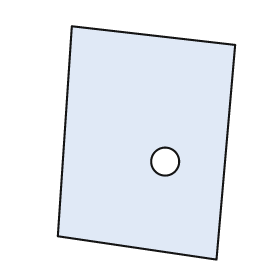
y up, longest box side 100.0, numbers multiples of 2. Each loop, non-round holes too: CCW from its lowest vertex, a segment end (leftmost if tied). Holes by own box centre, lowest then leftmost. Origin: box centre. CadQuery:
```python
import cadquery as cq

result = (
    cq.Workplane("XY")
    .moveTo(30.0, -50.0)
    .lineTo(38.0, 42.0)
    .lineTo(-32.0, 50.0)
    .lineTo(-38.0, -40.0)
    .close()
    .moveTo(8.0, -8.0)
    .circle(6.0)
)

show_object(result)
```